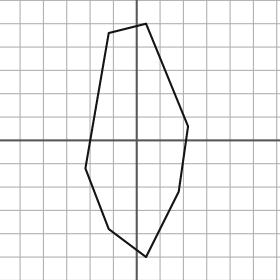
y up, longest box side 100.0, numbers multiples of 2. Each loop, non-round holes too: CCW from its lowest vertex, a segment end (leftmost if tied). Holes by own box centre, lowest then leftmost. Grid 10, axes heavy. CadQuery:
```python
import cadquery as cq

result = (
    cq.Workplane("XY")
    .moveTo(4.0, -50.0)
    .lineTo(18.0, -22.0)
    .lineTo(22.0, 6.0)
    .lineTo(4.0, 50.0)
    .lineTo(-12.0, 46.0)
    .lineTo(-22.0, -12.0)
    .lineTo(-12.0, -38.0)
    .close()
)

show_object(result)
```